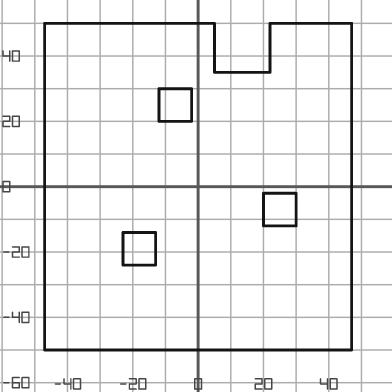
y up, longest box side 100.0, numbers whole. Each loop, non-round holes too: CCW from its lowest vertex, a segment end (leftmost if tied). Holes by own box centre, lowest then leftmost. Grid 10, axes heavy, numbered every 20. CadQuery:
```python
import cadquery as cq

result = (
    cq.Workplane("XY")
    .moveTo(-47.0, -50.0)
    .lineTo(47.0, -50.0)
    .lineTo(47.0, 50.0)
    .lineTo(22.0, 50.0)
    .lineTo(22.0, 35.0)
    .lineTo(5.0, 35.0)
    .lineTo(5.0, 50.0)
    .lineTo(-47.0, 50.0)
    .close()
    .moveTo(-23.0, -24.0)
    .lineTo(-13.0, -24.0)
    .lineTo(-13.0, -14.0)
    .lineTo(-23.0, -14.0)
    .close()
    .moveTo(20.0, -12.0)
    .lineTo(30.0, -12.0)
    .lineTo(30.0, -2.0)
    .lineTo(20.0, -2.0)
    .close()
    .moveTo(-12.0, 20.0)
    .lineTo(-2.0, 20.0)
    .lineTo(-2.0, 30.0)
    .lineTo(-12.0, 30.0)
    .close()
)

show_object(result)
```